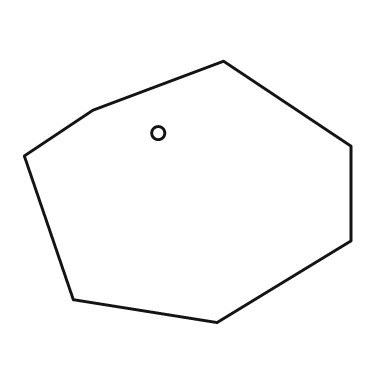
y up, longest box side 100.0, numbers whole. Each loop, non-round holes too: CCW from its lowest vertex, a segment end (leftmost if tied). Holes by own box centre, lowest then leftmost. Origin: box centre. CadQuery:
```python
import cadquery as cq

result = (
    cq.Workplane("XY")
    .moveTo(9.0, -40.0)
    .lineTo(50.0, -15.0)
    .lineTo(50.0, 14.0)
    .lineTo(11.0, 40.0)
    .lineTo(-29.0, 25.0)
    .lineTo(-50.0, 11.0)
    .lineTo(-35.0, -33.0)
    .close()
    .moveTo(-9.0, 18.0)
    .circle(2.0)
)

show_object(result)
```